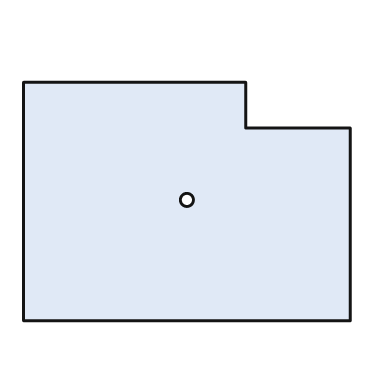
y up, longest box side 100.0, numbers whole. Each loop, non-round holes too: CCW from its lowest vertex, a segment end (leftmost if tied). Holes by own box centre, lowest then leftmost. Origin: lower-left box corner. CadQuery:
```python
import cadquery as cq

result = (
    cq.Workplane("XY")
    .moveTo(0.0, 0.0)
    .lineTo(100.0, 0.0)
    .lineTo(100.0, 59.0)
    .lineTo(68.0, 59.0)
    .lineTo(68.0, 73.0)
    .lineTo(0.0, 73.0)
    .close()
    .moveTo(50.0, 37.0)
    .circle(2.0)
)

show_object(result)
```